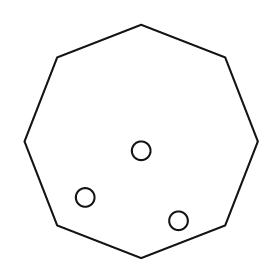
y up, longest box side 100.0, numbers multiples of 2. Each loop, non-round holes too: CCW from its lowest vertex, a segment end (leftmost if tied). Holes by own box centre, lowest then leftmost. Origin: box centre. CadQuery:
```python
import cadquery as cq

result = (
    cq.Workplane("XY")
    .moveTo(0.0, -50.0)
    .lineTo(36.0, -36.0)
    .lineTo(50.0, 0.0)
    .lineTo(36.0, 36.0)
    .lineTo(0.0, 50.0)
    .lineTo(-36.0, 36.0)
    .lineTo(-50.0, 0.0)
    .lineTo(-36.0, -36.0)
    .close()
    .moveTo(16.0, -34.0)
    .circle(4.0)
    .moveTo(-24.0, -24.0)
    .circle(4.0)
    .moveTo(0.0, -4.0)
    .circle(4.0)
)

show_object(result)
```